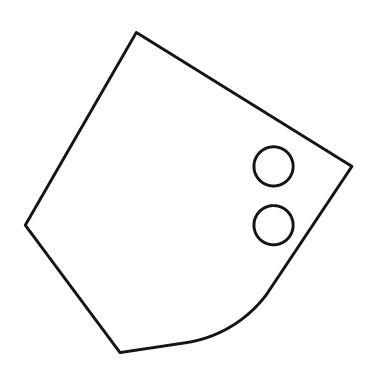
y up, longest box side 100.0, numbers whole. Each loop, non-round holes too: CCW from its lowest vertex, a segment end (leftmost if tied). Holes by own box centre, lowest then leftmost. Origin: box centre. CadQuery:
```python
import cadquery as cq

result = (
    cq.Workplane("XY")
    .moveTo(-21.0, -49.0)
    .lineTo(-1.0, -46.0)
    .threePointArc((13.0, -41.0), (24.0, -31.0))
    .lineTo(50.0, 8.0)
    .lineTo(-16.0, 49.0)
    .lineTo(-50.0, -10.0)
    .close()
    .moveTo(26.0, -10.0)
    .circle(6.0)
    .moveTo(26.0, 8.0)
    .circle(6.0)
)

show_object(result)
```